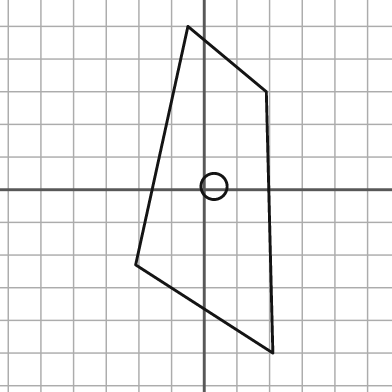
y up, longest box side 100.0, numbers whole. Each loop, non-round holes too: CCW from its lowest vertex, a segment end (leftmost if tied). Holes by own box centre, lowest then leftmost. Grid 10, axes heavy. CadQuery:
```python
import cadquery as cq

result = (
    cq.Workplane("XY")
    .moveTo(21.0, -50.0)
    .lineTo(19.0, 30.0)
    .lineTo(-5.0, 50.0)
    .lineTo(-21.0, -23.0)
    .close()
    .moveTo(3.0, 1.0)
    .circle(4.0)
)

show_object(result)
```